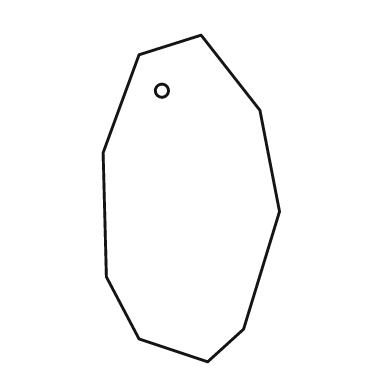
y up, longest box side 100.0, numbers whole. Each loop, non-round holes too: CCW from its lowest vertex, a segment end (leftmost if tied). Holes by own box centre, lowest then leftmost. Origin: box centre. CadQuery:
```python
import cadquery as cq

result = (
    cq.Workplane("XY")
    .moveTo(5.0, -50.0)
    .lineTo(16.0, -40.0)
    .lineTo(27.0, -4.0)
    .lineTo(21.0, 27.0)
    .lineTo(3.0, 50.0)
    .lineTo(-16.0, 44.0)
    .lineTo(-27.0, 14.0)
    .lineTo(-26.0, -24.0)
    .lineTo(-16.0, -43.0)
    .close()
    .moveTo(-9.0, 33.0)
    .circle(2.0)
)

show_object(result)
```